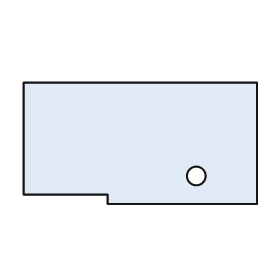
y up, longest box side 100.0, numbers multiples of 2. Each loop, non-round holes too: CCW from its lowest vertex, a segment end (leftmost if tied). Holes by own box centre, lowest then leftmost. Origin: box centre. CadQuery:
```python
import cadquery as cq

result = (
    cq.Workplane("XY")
    .moveTo(-14.0, -26.0)
    .lineTo(50.0, -26.0)
    .lineTo(50.0, 26.0)
    .lineTo(-50.0, 26.0)
    .lineTo(-50.0, -22.0)
    .lineTo(-14.0, -22.0)
    .close()
    .moveTo(24.0, -14.0)
    .circle(4.0)
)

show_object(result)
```